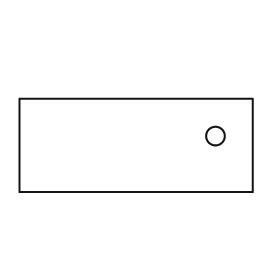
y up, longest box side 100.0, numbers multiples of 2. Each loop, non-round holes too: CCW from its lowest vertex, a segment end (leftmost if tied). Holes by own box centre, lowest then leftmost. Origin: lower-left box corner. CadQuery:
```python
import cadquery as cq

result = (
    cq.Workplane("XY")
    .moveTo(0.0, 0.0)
    .lineTo(100.0, 0.0)
    .lineTo(100.0, 40.0)
    .lineTo(0.0, 40.0)
    .close()
    .moveTo(84.0, 24.0)
    .circle(4.0)
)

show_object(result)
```